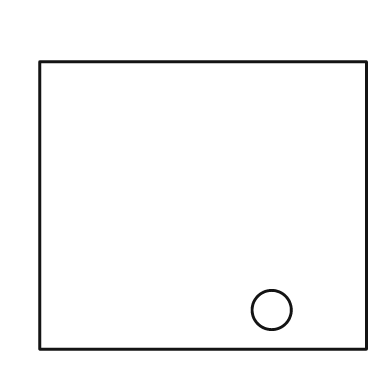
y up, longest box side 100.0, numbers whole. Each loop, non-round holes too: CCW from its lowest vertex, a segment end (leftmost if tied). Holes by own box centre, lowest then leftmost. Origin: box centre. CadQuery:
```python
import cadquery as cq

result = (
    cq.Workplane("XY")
    .moveTo(-50.0, -44.0)
    .lineTo(50.0, -44.0)
    .lineTo(50.0, 44.0)
    .lineTo(-50.0, 44.0)
    .close()
    .moveTo(21.0, -32.0)
    .circle(6.0)
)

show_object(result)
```